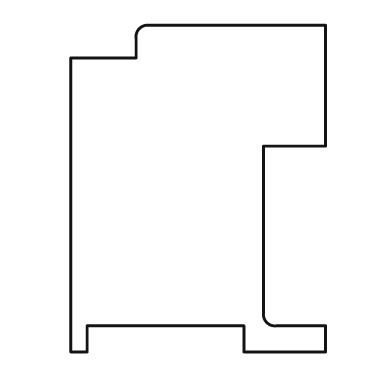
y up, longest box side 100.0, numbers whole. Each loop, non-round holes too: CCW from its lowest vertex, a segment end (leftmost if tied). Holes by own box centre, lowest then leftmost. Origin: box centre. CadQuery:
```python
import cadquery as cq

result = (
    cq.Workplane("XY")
    .moveTo(-39.0, -50.0)
    .lineTo(-34.0, -50.0)
    .lineTo(-34.0, -42.0)
    .lineTo(14.0, -42.0)
    .lineTo(14.0, -50.0)
    .lineTo(39.0, -50.0)
    .lineTo(39.0, -42.0)
    .lineTo(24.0, -42.0)
    .threePointArc((21.0, -41.0), (20.0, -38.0))
    .lineTo(20.0, 13.0)
    .lineTo(39.0, 13.0)
    .lineTo(39.0, 50.0)
    .lineTo(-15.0, 50.0)
    .threePointArc((-18.0, 49.0), (-19.0, 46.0))
    .lineTo(-19.0, 40.0)
    .lineTo(-39.0, 40.0)
    .close()
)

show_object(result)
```